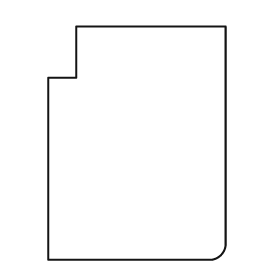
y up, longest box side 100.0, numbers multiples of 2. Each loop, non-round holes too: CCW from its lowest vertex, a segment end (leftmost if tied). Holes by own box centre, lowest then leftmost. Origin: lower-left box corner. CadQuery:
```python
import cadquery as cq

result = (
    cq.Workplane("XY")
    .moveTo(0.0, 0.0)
    .lineTo(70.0, 0.0)
    .threePointArc((74.0, 2.0), (76.0, 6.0))
    .lineTo(76.0, 100.0)
    .lineTo(12.0, 100.0)
    .lineTo(12.0, 78.0)
    .lineTo(0.0, 78.0)
    .close()
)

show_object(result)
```